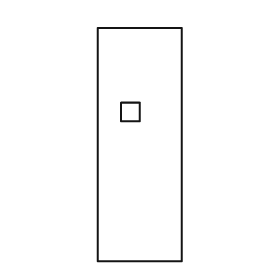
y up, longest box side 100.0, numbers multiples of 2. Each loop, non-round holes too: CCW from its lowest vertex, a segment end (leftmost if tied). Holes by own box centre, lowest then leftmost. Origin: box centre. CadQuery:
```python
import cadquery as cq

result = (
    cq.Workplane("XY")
    .moveTo(-18.0, -50.0)
    .lineTo(18.0, -50.0)
    .lineTo(18.0, 50.0)
    .lineTo(-18.0, 50.0)
    .close()
    .moveTo(-8.0, 10.0)
    .lineTo(0.0, 10.0)
    .lineTo(0.0, 18.0)
    .lineTo(-8.0, 18.0)
    .close()
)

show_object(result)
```